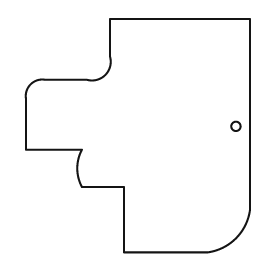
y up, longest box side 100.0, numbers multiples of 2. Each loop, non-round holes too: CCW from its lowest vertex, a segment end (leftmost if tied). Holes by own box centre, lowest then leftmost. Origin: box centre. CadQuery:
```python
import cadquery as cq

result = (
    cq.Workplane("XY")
    .moveTo(-6.0, -50.0)
    .lineTo(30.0, -50.0)
    .threePointArc((42.0, -44.0), (48.0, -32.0))
    .lineTo(48.0, 50.0)
    .lineTo(-12.0, 50.0)
    .lineTo(-12.0, 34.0)
    .threePointArc((-14.0, 26.0), (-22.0, 24.0))
    .lineTo(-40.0, 24.0)
    .threePointArc((-46.0, 22.0), (-48.0, 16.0))
    .lineTo(-48.0, -6.0)
    .lineTo(-24.0, -6.0)
    .threePointArc((-26.0, -14.0), (-24.0, -22.0))
    .lineTo(-6.0, -22.0)
    .close()
    .moveTo(42.0, 4.0)
    .circle(2.0)
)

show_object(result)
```